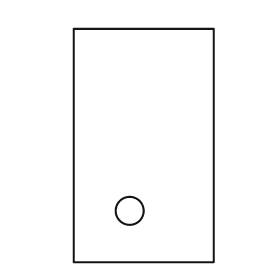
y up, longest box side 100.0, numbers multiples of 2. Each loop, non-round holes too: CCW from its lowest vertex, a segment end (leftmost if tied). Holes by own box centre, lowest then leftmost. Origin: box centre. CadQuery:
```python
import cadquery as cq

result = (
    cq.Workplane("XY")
    .moveTo(-30.0, -50.0)
    .lineTo(30.0, -50.0)
    .lineTo(30.0, 50.0)
    .lineTo(-30.0, 50.0)
    .close()
    .moveTo(-6.0, -28.0)
    .circle(6.0)
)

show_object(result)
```